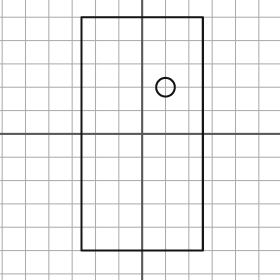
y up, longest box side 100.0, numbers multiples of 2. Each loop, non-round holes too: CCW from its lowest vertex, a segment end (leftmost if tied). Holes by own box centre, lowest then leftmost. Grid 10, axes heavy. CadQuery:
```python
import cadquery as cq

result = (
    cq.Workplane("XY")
    .moveTo(-26.0, -50.0)
    .lineTo(26.0, -50.0)
    .lineTo(26.0, 50.0)
    .lineTo(-26.0, 50.0)
    .close()
    .moveTo(10.0, 20.0)
    .circle(4.0)
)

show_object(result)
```